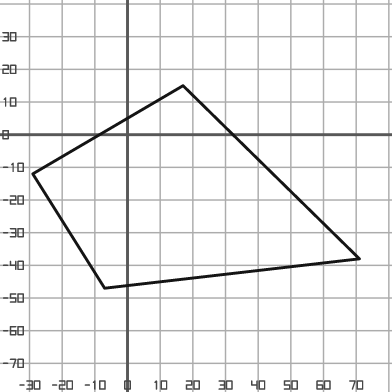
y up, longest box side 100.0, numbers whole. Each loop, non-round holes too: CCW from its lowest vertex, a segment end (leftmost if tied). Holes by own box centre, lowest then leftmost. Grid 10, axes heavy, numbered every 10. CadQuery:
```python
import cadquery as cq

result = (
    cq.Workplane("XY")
    .moveTo(-7.0, -47.0)
    .lineTo(71.0, -38.0)
    .lineTo(17.0, 15.0)
    .lineTo(-29.0, -12.0)
    .close()
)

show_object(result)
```